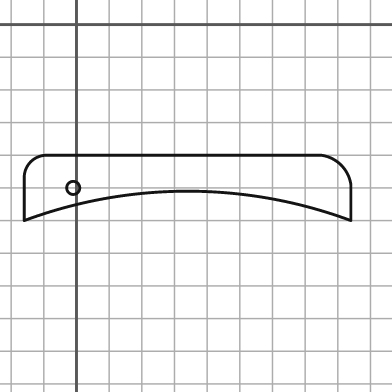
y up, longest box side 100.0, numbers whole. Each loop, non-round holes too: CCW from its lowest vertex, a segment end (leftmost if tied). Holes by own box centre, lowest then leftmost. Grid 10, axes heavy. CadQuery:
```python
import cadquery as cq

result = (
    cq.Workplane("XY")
    .moveTo(-16.0, -60.0)
    .threePointArc((34.0, -51.0), (84.0, -60.0))
    .lineTo(84.0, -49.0)
    .threePointArc((81.0, -43.0), (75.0, -40.0))
    .lineTo(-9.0, -40.0)
    .threePointArc((-14.0, -42.0), (-16.0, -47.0))
    .close()
    .moveTo(-1.0, -50.0)
    .circle(2.0)
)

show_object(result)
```